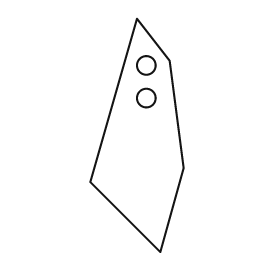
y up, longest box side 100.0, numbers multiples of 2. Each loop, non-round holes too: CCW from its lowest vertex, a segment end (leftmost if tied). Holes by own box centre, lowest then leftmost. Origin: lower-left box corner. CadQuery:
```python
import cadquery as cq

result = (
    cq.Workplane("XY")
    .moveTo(30.0, 0.0)
    .lineTo(40.0, 36.0)
    .lineTo(34.0, 82.0)
    .lineTo(20.0, 100.0)
    .lineTo(0.0, 30.0)
    .close()
    .moveTo(24.0, 66.0)
    .circle(4.0)
    .moveTo(24.0, 80.0)
    .circle(4.0)
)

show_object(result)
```